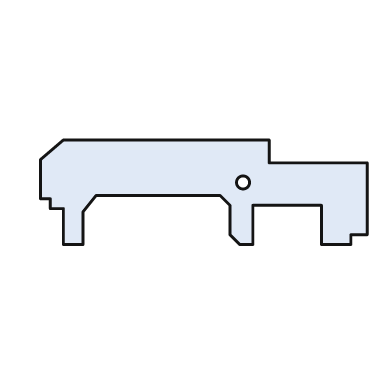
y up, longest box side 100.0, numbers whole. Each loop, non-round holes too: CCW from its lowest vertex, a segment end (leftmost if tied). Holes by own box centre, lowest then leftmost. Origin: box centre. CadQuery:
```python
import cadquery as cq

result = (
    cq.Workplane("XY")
    .moveTo(-43.0, -16.0)
    .lineTo(-37.0, -16.0)
    .lineTo(-37.0, -6.0)
    .lineTo(-33.0, -1.0)
    .lineTo(5.0, -1.0)
    .lineTo(8.0, -4.0)
    .lineTo(8.0, -13.0)
    .lineTo(11.0, -16.0)
    .lineTo(15.0, -16.0)
    .lineTo(15.0, -4.0)
    .lineTo(36.0, -4.0)
    .lineTo(36.0, -16.0)
    .lineTo(45.0, -16.0)
    .lineTo(45.0, -13.0)
    .lineTo(50.0, -13.0)
    .lineTo(50.0, 9.0)
    .lineTo(20.0, 9.0)
    .lineTo(20.0, 16.0)
    .lineTo(-43.0, 16.0)
    .lineTo(-50.0, 10.0)
    .lineTo(-50.0, -2.0)
    .lineTo(-47.0, -2.0)
    .lineTo(-47.0, -5.0)
    .lineTo(-43.0, -5.0)
    .close()
    .moveTo(12.0, 3.0)
    .circle(2.0)
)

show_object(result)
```